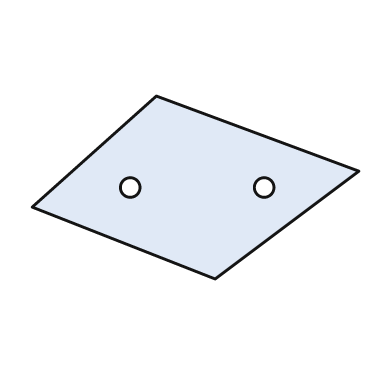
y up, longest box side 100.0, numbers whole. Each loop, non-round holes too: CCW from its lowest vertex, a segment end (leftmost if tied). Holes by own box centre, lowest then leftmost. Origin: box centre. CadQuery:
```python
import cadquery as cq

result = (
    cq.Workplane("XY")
    .moveTo(6.0, -28.0)
    .lineTo(50.0, 5.0)
    .lineTo(-12.0, 28.0)
    .lineTo(-50.0, -6.0)
    .close()
    .moveTo(-20.0, 0.0)
    .circle(3.0)
    .moveTo(21.0, 0.0)
    .circle(3.0)
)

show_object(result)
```